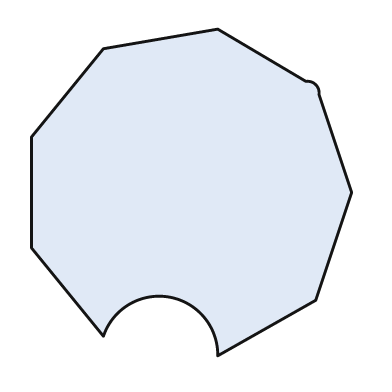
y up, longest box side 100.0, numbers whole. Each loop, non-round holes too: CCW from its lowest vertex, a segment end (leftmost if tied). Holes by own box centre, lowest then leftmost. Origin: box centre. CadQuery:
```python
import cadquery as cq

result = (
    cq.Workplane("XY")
    .moveTo(8.0, -50.0)
    .lineTo(38.0, -33.0)
    .lineTo(49.0, 0.0)
    .lineTo(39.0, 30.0)
    .threePointArc((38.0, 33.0), (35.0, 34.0))
    .lineTo(8.0, 50.0)
    .lineTo(-27.0, 44.0)
    .lineTo(-49.0, 17.0)
    .lineTo(-49.0, -17.0)
    .lineTo(-27.0, -44.0)
    .threePointArc((-7.0, -32.0), (8.0, -50.0))
    .close()
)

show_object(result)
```